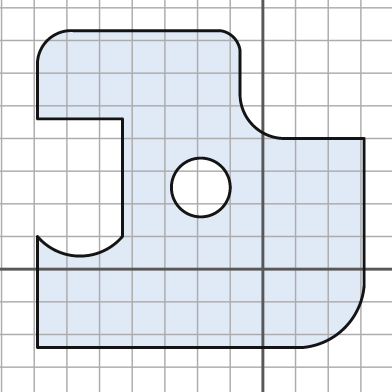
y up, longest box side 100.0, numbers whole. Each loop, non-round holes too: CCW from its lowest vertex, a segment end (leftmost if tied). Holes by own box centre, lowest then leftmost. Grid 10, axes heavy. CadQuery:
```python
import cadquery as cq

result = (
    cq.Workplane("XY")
    .moveTo(-69.0, -24.0)
    .lineTo(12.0, -24.0)
    .threePointArc((25.0, -18.0), (31.0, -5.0))
    .lineTo(31.0, 40.0)
    .lineTo(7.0, 40.0)
    .threePointArc((-3.0, 44.0), (-7.0, 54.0))
    .lineTo(-7.0, 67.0)
    .threePointArc((-9.0, 71.0), (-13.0, 73.0))
    .lineTo(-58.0, 73.0)
    .threePointArc((-66.0, 70.0), (-69.0, 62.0))
    .lineTo(-69.0, 46.0)
    .lineTo(-43.0, 46.0)
    .lineTo(-43.0, 10.0)
    .threePointArc((-56.0, 4.0), (-69.0, 10.0))
    .close()
    .moveTo(-19.0, 25.0)
    .circle(9.0)
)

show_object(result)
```